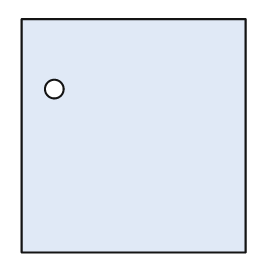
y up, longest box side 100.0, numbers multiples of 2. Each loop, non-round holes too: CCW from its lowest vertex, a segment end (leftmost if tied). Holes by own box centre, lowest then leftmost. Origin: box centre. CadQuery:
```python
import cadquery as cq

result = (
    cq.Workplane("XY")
    .moveTo(-48.0, -50.0)
    .lineTo(48.0, -50.0)
    .lineTo(48.0, 50.0)
    .lineTo(-48.0, 50.0)
    .close()
    .moveTo(-34.0, 20.0)
    .circle(4.0)
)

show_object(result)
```